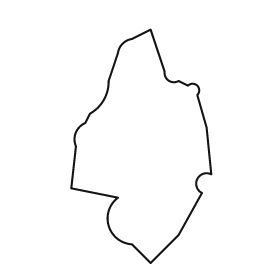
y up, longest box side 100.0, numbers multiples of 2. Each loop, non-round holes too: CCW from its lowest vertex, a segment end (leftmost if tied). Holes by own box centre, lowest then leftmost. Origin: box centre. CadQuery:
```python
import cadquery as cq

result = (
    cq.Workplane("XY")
    .moveTo(4.0, -50.0)
    .lineTo(16.0, -38.0)
    .lineTo(26.0, -20.0)
    .threePointArc((24.0, -14.0), (30.0, -12.0))
    .lineTo(28.0, 8.0)
    .lineTo(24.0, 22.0)
    .threePointArc((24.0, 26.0), (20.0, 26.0))
    .lineTo(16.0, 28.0)
    .threePointArc((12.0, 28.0), (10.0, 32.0))
    .lineTo(4.0, 50.0)
    .lineTo(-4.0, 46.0)
    .threePointArc((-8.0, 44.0), (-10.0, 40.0))
    .lineTo(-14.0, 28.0)
    .threePointArc((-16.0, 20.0), (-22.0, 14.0))
    .lineTo(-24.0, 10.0)
    .threePointArc((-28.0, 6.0), (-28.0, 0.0))
    .lineTo(-30.0, -18.0)
    .lineTo(-10.0, -22.0)
    .threePointArc((-14.0, -34.0), (-4.0, -42.0))
    .close()
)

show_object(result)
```